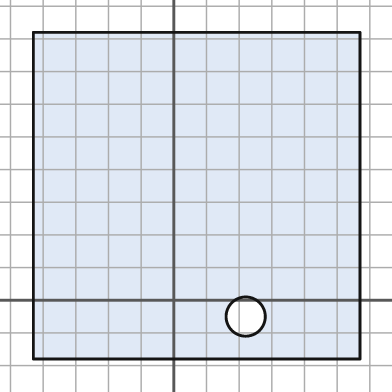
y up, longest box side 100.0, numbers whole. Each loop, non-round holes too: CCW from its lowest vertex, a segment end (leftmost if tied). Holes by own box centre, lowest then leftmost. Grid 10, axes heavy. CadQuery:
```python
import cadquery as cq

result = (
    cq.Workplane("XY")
    .moveTo(-43.0, -18.0)
    .lineTo(57.0, -18.0)
    .lineTo(57.0, 82.0)
    .lineTo(-43.0, 82.0)
    .close()
    .moveTo(22.0, -5.0)
    .circle(6.0)
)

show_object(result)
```